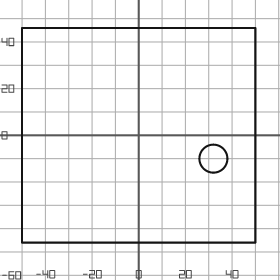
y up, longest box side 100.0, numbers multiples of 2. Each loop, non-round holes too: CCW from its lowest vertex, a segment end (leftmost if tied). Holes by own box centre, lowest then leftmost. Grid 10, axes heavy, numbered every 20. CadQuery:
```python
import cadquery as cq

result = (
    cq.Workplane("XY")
    .moveTo(-50.0, -46.0)
    .lineTo(50.0, -46.0)
    .lineTo(50.0, 46.0)
    .lineTo(-50.0, 46.0)
    .close()
    .moveTo(32.0, -10.0)
    .circle(6.0)
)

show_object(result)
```